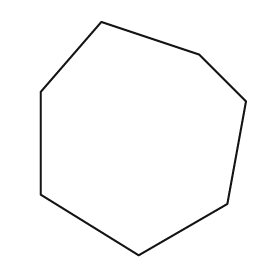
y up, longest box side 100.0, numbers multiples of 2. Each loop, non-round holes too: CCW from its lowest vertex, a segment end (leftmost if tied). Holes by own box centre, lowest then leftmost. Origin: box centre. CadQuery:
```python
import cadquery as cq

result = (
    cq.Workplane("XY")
    .moveTo(-2.0, -50.0)
    .lineTo(36.0, -28.0)
    .lineTo(44.0, 16.0)
    .lineTo(24.0, 36.0)
    .lineTo(-18.0, 50.0)
    .lineTo(-44.0, 20.0)
    .lineTo(-44.0, -24.0)
    .close()
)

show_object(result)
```